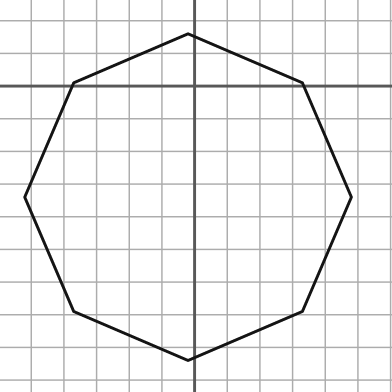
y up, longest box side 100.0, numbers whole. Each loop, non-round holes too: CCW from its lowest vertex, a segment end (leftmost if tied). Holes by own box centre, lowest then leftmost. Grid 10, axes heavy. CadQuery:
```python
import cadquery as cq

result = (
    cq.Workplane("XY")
    .moveTo(-2.0, -84.0)
    .lineTo(33.0, -69.0)
    .lineTo(48.0, -34.0)
    .lineTo(33.0, 1.0)
    .lineTo(-2.0, 16.0)
    .lineTo(-37.0, 1.0)
    .lineTo(-52.0, -34.0)
    .lineTo(-37.0, -69.0)
    .close()
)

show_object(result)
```